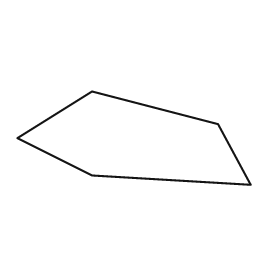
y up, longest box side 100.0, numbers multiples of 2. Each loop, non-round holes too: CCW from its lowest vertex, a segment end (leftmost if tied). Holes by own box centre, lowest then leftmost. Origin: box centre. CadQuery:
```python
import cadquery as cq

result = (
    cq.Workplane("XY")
    .moveTo(50.0, -20.0)
    .lineTo(36.0, 6.0)
    .lineTo(-18.0, 20.0)
    .lineTo(-50.0, 0.0)
    .lineTo(-18.0, -16.0)
    .close()
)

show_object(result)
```